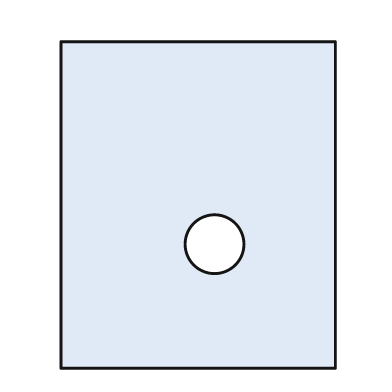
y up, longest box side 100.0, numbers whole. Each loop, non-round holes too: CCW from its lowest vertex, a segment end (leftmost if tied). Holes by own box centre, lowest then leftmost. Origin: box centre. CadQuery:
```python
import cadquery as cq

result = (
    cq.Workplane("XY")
    .moveTo(-42.0, -50.0)
    .lineTo(42.0, -50.0)
    .lineTo(42.0, 50.0)
    .lineTo(-42.0, 50.0)
    .close()
    .moveTo(5.0, -12.0)
    .circle(9.0)
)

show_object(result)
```